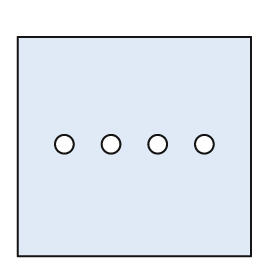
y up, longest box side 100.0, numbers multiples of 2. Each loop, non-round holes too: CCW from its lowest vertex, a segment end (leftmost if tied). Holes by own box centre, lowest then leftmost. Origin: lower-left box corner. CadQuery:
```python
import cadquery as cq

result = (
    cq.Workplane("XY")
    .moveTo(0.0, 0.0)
    .lineTo(100.0, 0.0)
    .lineTo(100.0, 94.0)
    .lineTo(0.0, 94.0)
    .close()
    .moveTo(20.0, 48.0)
    .circle(4.0)
    .moveTo(40.0, 48.0)
    .circle(4.0)
    .moveTo(60.0, 48.0)
    .circle(4.0)
    .moveTo(80.0, 48.0)
    .circle(4.0)
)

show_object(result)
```